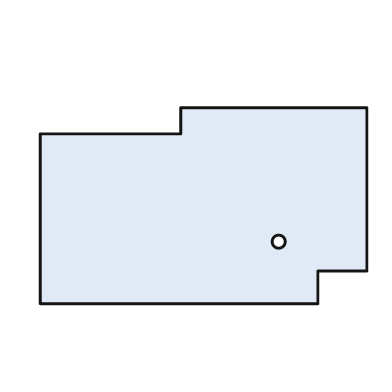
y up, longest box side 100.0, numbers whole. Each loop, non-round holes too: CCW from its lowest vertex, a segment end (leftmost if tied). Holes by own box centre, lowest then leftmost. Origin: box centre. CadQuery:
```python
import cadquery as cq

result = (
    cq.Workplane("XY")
    .moveTo(-50.0, -30.0)
    .lineTo(35.0, -30.0)
    .lineTo(35.0, -20.0)
    .lineTo(50.0, -20.0)
    .lineTo(50.0, 30.0)
    .lineTo(-7.0, 30.0)
    .lineTo(-7.0, 22.0)
    .lineTo(-50.0, 22.0)
    .close()
    .moveTo(23.0, -11.0)
    .circle(2.0)
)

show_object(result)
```